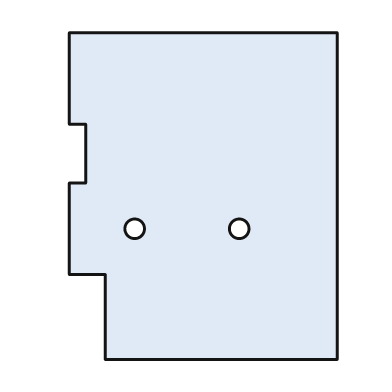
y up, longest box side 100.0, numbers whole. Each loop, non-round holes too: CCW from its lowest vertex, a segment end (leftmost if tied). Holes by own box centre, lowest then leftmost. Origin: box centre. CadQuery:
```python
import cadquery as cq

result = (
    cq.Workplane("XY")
    .moveTo(-30.0, -50.0)
    .lineTo(41.0, -50.0)
    .lineTo(41.0, 50.0)
    .lineTo(-41.0, 50.0)
    .lineTo(-41.0, 22.0)
    .lineTo(-36.0, 22.0)
    .lineTo(-36.0, 4.0)
    .lineTo(-41.0, 4.0)
    .lineTo(-41.0, -24.0)
    .lineTo(-30.0, -24.0)
    .close()
    .moveTo(-21.0, -10.0)
    .circle(3.0)
    .moveTo(11.0, -10.0)
    .circle(3.0)
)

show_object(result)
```